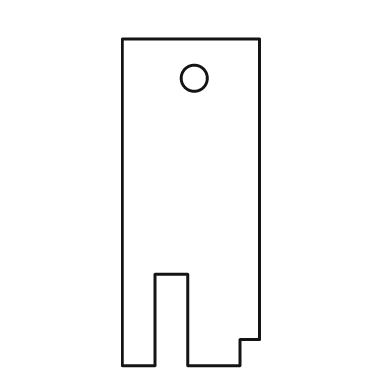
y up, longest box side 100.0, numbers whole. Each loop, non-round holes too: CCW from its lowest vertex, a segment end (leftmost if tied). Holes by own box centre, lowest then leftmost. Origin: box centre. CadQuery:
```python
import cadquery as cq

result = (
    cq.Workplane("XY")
    .moveTo(-21.0, -50.0)
    .lineTo(-11.0, -50.0)
    .lineTo(-11.0, -22.0)
    .lineTo(-1.0, -22.0)
    .lineTo(-1.0, -50.0)
    .lineTo(15.0, -50.0)
    .lineTo(15.0, -42.0)
    .lineTo(21.0, -42.0)
    .lineTo(21.0, 50.0)
    .lineTo(-21.0, 50.0)
    .close()
    .moveTo(1.0, 38.0)
    .circle(4.0)
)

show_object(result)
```